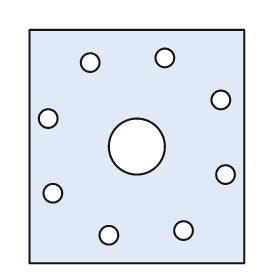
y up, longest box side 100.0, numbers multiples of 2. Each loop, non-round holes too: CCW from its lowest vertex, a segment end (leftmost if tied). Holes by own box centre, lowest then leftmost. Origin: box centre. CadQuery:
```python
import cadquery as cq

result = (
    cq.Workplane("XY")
    .moveTo(-46.0, -50.0)
    .lineTo(46.0, -50.0)
    .lineTo(46.0, 50.0)
    .lineTo(-46.0, 50.0)
    .close()
    .moveTo(-12.0, -38.0)
    .circle(4.0)
    .moveTo(20.0, -36.0)
    .circle(4.0)
    .moveTo(-36.0, -20.0)
    .circle(4.0)
    .moveTo(38.0, -12.0)
    .circle(4.0)
    .moveTo(0.0, 0.0)
    .circle(12.0)
    .moveTo(-38.0, 12.0)
    .circle(4.0)
    .moveTo(36.0, 20.0)
    .circle(4.0)
    .moveTo(-20.0, 36.0)
    .circle(4.0)
    .moveTo(12.0, 38.0)
    .circle(4.0)
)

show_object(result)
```